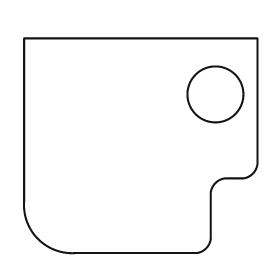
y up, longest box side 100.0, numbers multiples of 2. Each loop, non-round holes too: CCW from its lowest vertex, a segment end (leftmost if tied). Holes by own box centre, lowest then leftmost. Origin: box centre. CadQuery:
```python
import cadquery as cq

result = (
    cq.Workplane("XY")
    .moveTo(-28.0, -46.0)
    .lineTo(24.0, -46.0)
    .threePointArc((28.0, -44.0), (30.0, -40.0))
    .lineTo(30.0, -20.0)
    .threePointArc((32.0, -16.0), (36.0, -14.0))
    .lineTo(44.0, -14.0)
    .threePointArc((48.0, -12.0), (50.0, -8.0))
    .lineTo(50.0, 46.0)
    .lineTo(-50.0, 46.0)
    .lineTo(-50.0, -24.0)
    .threePointArc((-44.0, -40.0), (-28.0, -46.0))
    .close()
    .moveTo(32.0, 22.0)
    .circle(12.0)
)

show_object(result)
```